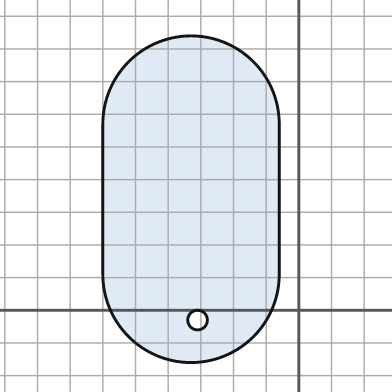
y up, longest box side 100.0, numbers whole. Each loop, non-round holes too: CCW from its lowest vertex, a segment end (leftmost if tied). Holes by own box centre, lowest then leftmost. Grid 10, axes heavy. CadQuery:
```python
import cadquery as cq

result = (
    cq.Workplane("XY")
    .moveTo(-60.0, 11.0)
    .threePointArc((-33.0, -16.0), (-6.0, 11.0))
    .lineTo(-6.0, 57.0)
    .threePointArc((-33.0, 84.0), (-60.0, 57.0))
    .close()
    .moveTo(-31.0, -3.0)
    .circle(3.0)
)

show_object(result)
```